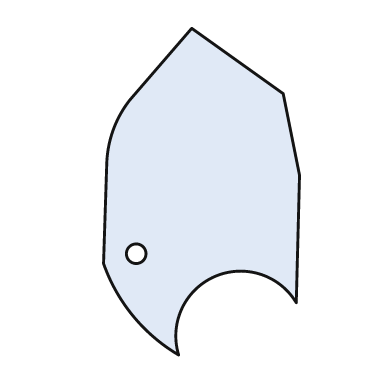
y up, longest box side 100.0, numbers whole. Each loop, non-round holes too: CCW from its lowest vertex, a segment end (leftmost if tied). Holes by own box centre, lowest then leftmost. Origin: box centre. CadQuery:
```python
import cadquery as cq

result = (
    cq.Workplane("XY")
    .moveTo(-7.0, -50.0)
    .threePointArc((4.0, -26.0), (29.0, -34.0))
    .lineTo(30.0, 5.0)
    .lineTo(25.0, 30.0)
    .lineTo(-3.0, 50.0)
    .lineTo(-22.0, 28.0)
    .threePointArc((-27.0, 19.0), (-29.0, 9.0))
    .lineTo(-30.0, -22.0)
    .threePointArc((-21.0, -38.0), (-7.0, -50.0))
    .close()
    .moveTo(-20.0, -19.0)
    .circle(3.0)
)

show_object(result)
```